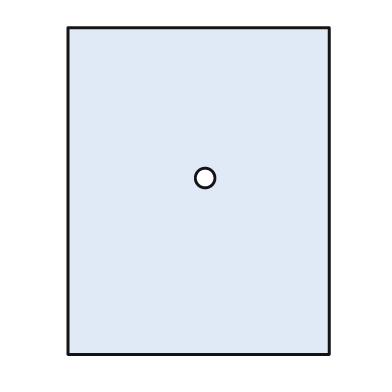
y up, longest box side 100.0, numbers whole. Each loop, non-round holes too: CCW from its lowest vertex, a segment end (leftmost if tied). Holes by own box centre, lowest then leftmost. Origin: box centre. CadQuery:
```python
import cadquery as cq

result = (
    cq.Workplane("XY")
    .moveTo(-40.0, -50.0)
    .lineTo(40.0, -50.0)
    .lineTo(40.0, 50.0)
    .lineTo(-40.0, 50.0)
    .close()
    .moveTo(2.0, 4.0)
    .circle(3.0)
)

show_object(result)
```